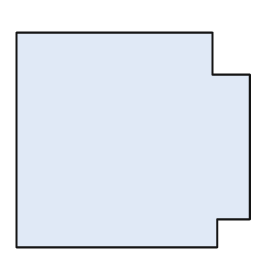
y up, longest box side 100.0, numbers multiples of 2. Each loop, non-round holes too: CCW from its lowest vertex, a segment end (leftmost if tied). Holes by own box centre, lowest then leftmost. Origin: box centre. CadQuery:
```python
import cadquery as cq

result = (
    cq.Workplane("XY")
    .moveTo(-50.0, -46.0)
    .lineTo(36.0, -46.0)
    .lineTo(36.0, -34.0)
    .lineTo(50.0, -34.0)
    .lineTo(50.0, 28.0)
    .lineTo(34.0, 28.0)
    .lineTo(34.0, 46.0)
    .lineTo(-50.0, 46.0)
    .close()
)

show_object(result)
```